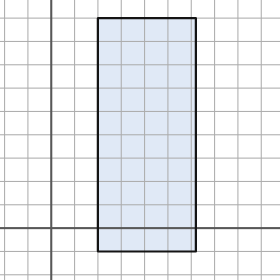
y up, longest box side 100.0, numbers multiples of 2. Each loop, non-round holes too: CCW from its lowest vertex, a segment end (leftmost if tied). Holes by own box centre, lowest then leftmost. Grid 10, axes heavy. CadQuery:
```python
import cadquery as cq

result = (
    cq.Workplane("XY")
    .moveTo(20.0, -10.0)
    .lineTo(62.0, -10.0)
    .lineTo(62.0, 90.0)
    .lineTo(20.0, 90.0)
    .close()
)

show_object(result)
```